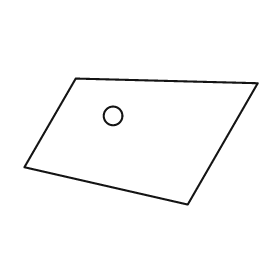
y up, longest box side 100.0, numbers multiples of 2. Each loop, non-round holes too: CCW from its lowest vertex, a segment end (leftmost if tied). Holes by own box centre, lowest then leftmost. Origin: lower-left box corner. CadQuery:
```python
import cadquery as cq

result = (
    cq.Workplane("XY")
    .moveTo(70.0, 0.0)
    .lineTo(100.0, 52.0)
    .lineTo(22.0, 54.0)
    .lineTo(0.0, 16.0)
    .close()
    .moveTo(38.0, 38.0)
    .circle(4.0)
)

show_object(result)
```